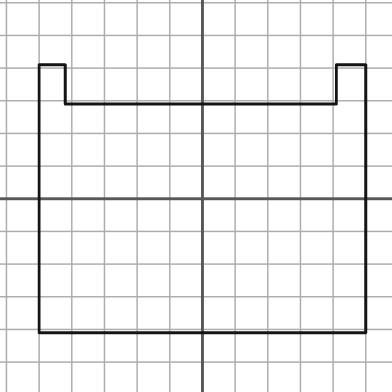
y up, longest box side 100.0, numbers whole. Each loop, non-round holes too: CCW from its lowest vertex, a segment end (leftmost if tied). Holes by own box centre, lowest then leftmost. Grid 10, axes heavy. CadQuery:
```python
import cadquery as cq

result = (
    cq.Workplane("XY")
    .moveTo(-50.0, -41.0)
    .lineTo(50.0, -41.0)
    .lineTo(50.0, 41.0)
    .lineTo(41.0, 41.0)
    .lineTo(41.0, 29.0)
    .lineTo(-42.0, 29.0)
    .lineTo(-42.0, 41.0)
    .lineTo(-50.0, 41.0)
    .close()
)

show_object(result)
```